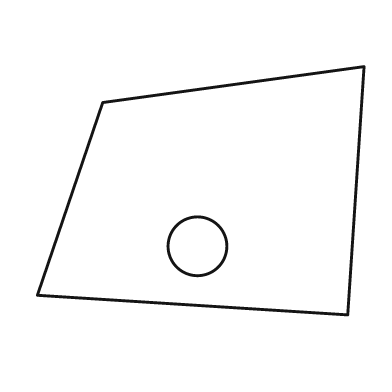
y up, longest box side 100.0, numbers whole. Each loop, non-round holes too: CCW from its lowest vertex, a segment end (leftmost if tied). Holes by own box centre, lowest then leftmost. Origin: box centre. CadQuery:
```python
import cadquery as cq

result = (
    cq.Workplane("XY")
    .moveTo(45.0, -38.0)
    .lineTo(50.0, 38.0)
    .lineTo(-30.0, 27.0)
    .lineTo(-50.0, -32.0)
    .close()
    .moveTo(-1.0, -17.0)
    .circle(9.0)
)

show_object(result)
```